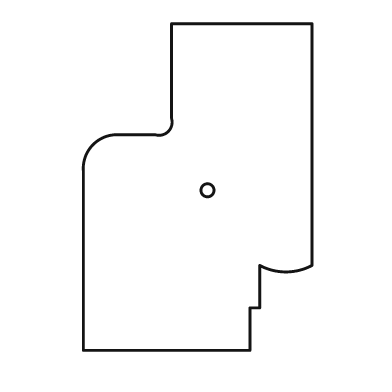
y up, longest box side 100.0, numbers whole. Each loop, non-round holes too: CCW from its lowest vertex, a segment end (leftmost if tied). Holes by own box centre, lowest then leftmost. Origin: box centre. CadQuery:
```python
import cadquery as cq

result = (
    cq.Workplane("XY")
    .moveTo(-35.0, -50.0)
    .lineTo(16.0, -50.0)
    .lineTo(16.0, -37.0)
    .lineTo(19.0, -37.0)
    .lineTo(19.0, -24.0)
    .threePointArc((27.0, -26.0), (35.0, -24.0))
    .lineTo(35.0, 50.0)
    .lineTo(-8.0, 50.0)
    .lineTo(-8.0, 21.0)
    .threePointArc((-9.0, 17.0), (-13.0, 16.0))
    .lineTo(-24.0, 16.0)
    .threePointArc((-32.0, 13.0), (-35.0, 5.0))
    .close()
    .moveTo(3.0, -1.0)
    .circle(2.0)
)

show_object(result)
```